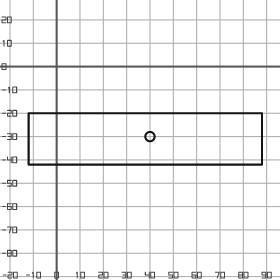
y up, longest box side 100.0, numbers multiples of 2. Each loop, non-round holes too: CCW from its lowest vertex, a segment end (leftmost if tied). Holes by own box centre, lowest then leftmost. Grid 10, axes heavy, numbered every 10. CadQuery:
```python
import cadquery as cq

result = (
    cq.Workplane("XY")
    .moveTo(-12.0, -42.0)
    .lineTo(88.0, -42.0)
    .lineTo(88.0, -20.0)
    .lineTo(-12.0, -20.0)
    .close()
    .moveTo(40.0, -30.0)
    .circle(2.0)
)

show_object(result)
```